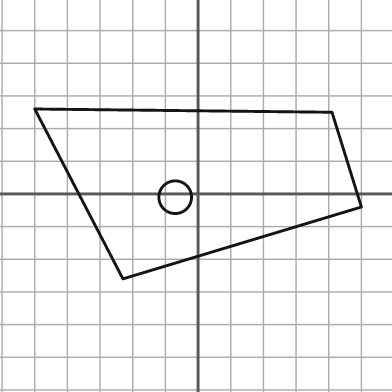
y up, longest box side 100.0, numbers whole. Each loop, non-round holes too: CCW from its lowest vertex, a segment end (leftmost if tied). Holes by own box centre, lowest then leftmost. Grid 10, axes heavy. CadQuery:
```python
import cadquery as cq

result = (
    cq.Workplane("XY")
    .moveTo(-23.0, -26.0)
    .lineTo(50.0, -4.0)
    .lineTo(41.0, 25.0)
    .lineTo(-50.0, 26.0)
    .close()
    .moveTo(-7.0, -1.0)
    .circle(5.0)
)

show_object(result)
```